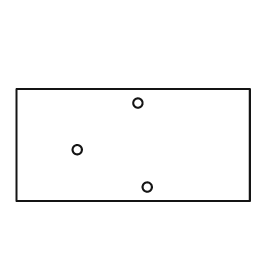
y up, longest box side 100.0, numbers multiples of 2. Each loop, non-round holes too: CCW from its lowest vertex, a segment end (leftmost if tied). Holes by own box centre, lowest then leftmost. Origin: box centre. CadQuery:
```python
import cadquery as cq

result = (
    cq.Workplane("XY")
    .moveTo(-50.0, -24.0)
    .lineTo(50.0, -24.0)
    .lineTo(50.0, 24.0)
    .lineTo(-50.0, 24.0)
    .close()
    .moveTo(6.0, -18.0)
    .circle(2.0)
    .moveTo(-24.0, -2.0)
    .circle(2.0)
    .moveTo(2.0, 18.0)
    .circle(2.0)
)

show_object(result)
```